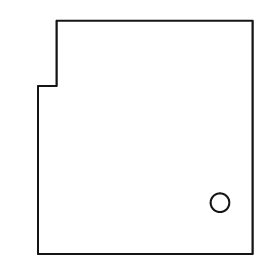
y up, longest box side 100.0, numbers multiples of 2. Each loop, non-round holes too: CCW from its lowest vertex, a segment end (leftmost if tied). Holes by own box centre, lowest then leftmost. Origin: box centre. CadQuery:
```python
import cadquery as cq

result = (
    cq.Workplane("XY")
    .moveTo(-46.0, -50.0)
    .lineTo(46.0, -50.0)
    .lineTo(46.0, 50.0)
    .lineTo(-38.0, 50.0)
    .lineTo(-38.0, 22.0)
    .lineTo(-46.0, 22.0)
    .close()
    .moveTo(32.0, -28.0)
    .circle(4.0)
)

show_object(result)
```